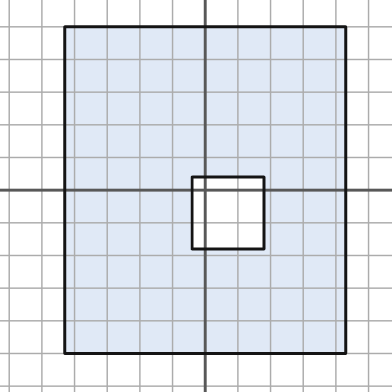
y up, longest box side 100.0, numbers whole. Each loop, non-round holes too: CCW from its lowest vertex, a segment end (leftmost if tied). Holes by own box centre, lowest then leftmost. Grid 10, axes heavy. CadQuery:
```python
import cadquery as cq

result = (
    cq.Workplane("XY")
    .moveTo(-43.0, -50.0)
    .lineTo(43.0, -50.0)
    .lineTo(43.0, 50.0)
    .lineTo(-43.0, 50.0)
    .close()
    .moveTo(-4.0, -18.0)
    .lineTo(18.0, -18.0)
    .lineTo(18.0, 4.0)
    .lineTo(-4.0, 4.0)
    .close()
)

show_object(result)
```